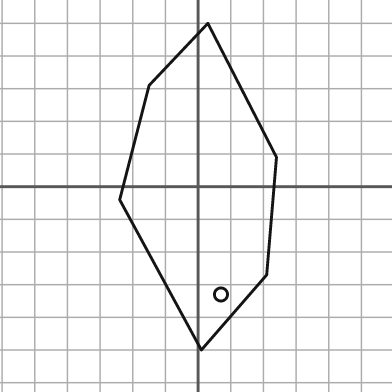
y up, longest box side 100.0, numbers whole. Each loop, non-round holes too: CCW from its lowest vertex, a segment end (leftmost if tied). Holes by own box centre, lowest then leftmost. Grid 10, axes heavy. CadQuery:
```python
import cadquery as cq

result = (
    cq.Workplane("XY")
    .moveTo(1.0, -50.0)
    .lineTo(21.0, -27.0)
    .lineTo(24.0, 9.0)
    .lineTo(3.0, 50.0)
    .lineTo(-15.0, 31.0)
    .lineTo(-24.0, -4.0)
    .close()
    .moveTo(7.0, -33.0)
    .circle(2.0)
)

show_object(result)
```